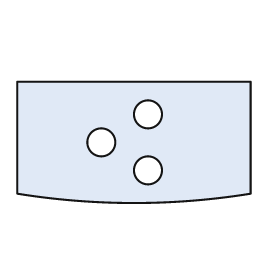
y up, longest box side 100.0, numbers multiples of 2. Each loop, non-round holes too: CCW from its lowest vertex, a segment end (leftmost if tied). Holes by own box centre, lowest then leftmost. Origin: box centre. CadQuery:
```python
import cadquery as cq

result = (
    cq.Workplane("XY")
    .moveTo(-50.0, -22.0)
    .threePointArc((0.0, -26.0), (50.0, -22.0))
    .lineTo(50.0, 26.0)
    .lineTo(-50.0, 26.0)
    .close()
    .moveTo(6.0, -12.0)
    .circle(6.0)
    .moveTo(-14.0, 0.0)
    .circle(6.0)
    .moveTo(6.0, 12.0)
    .circle(6.0)
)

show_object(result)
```